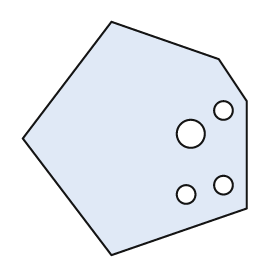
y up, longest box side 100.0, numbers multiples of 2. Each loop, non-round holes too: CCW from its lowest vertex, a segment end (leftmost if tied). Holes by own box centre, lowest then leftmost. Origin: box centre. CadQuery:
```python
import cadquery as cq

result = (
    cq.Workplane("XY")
    .moveTo(-10.0, -50.0)
    .lineTo(48.0, -30.0)
    .lineTo(48.0, 16.0)
    .lineTo(36.0, 34.0)
    .lineTo(-10.0, 50.0)
    .lineTo(-48.0, 0.0)
    .close()
    .moveTo(22.0, -24.0)
    .circle(4.0)
    .moveTo(38.0, -20.0)
    .circle(4.0)
    .moveTo(24.0, 2.0)
    .circle(6.0)
    .moveTo(38.0, 12.0)
    .circle(4.0)
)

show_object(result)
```